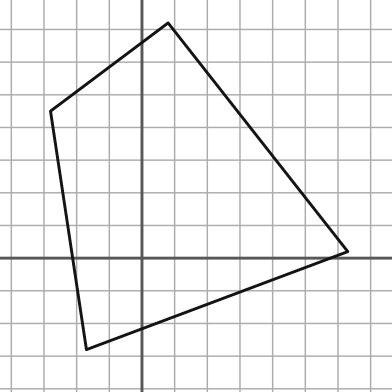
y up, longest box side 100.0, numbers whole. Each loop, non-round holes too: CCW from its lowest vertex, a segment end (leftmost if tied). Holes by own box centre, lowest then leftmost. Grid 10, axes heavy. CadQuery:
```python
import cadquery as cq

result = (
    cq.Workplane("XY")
    .moveTo(-17.0, -28.0)
    .lineTo(63.0, 2.0)
    .lineTo(8.0, 72.0)
    .lineTo(-28.0, 45.0)
    .close()
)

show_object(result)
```